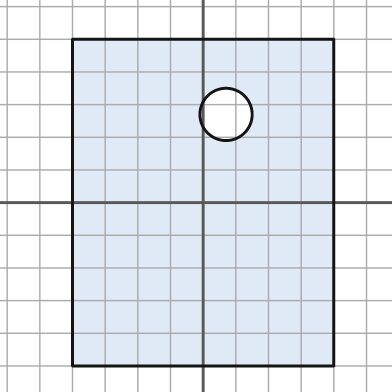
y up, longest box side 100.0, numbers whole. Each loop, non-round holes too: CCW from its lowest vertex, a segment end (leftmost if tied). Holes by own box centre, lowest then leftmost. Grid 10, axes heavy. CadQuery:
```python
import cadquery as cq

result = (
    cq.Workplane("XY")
    .moveTo(-40.0, -50.0)
    .lineTo(40.0, -50.0)
    .lineTo(40.0, 50.0)
    .lineTo(-40.0, 50.0)
    .close()
    .moveTo(7.0, 27.0)
    .circle(8.0)
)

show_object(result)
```